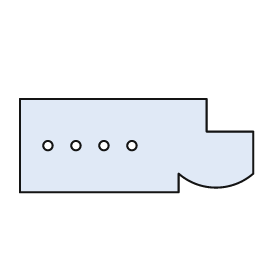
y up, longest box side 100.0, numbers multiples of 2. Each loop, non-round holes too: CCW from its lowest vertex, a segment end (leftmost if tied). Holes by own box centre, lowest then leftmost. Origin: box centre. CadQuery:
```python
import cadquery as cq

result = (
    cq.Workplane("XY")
    .moveTo(-50.0, -20.0)
    .lineTo(18.0, -20.0)
    .lineTo(18.0, -12.0)
    .threePointArc((34.0, -18.0), (50.0, -12.0))
    .lineTo(50.0, 6.0)
    .lineTo(30.0, 6.0)
    .lineTo(30.0, 20.0)
    .lineTo(-50.0, 20.0)
    .close()
    .moveTo(-38.0, 0.0)
    .circle(2.0)
    .moveTo(-26.0, 0.0)
    .circle(2.0)
    .moveTo(-14.0, 0.0)
    .circle(2.0)
    .moveTo(-2.0, 0.0)
    .circle(2.0)
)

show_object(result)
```